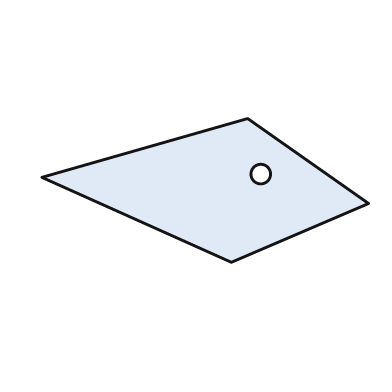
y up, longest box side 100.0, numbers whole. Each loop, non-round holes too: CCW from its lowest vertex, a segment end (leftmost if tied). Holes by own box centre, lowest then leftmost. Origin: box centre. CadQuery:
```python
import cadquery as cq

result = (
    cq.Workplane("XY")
    .moveTo(8.0, -22.0)
    .lineTo(50.0, -4.0)
    .lineTo(13.0, 22.0)
    .lineTo(-50.0, 4.0)
    .close()
    .moveTo(17.0, 5.0)
    .circle(3.0)
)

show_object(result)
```